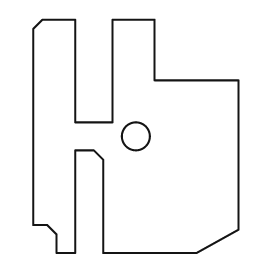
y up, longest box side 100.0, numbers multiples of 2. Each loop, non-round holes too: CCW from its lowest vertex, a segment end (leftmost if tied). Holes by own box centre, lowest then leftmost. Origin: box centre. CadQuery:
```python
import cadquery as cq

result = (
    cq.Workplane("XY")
    .moveTo(-34.0, -50.0)
    .lineTo(-26.0, -50.0)
    .lineTo(-26.0, -6.0)
    .lineTo(-18.0, -6.0)
    .lineTo(-14.0, -10.0)
    .lineTo(-14.0, -50.0)
    .lineTo(26.0, -50.0)
    .lineTo(44.0, -40.0)
    .lineTo(44.0, 24.0)
    .lineTo(8.0, 24.0)
    .lineTo(8.0, 50.0)
    .lineTo(-10.0, 50.0)
    .lineTo(-10.0, 6.0)
    .lineTo(-26.0, 6.0)
    .lineTo(-26.0, 50.0)
    .lineTo(-40.0, 50.0)
    .lineTo(-44.0, 46.0)
    .lineTo(-44.0, -38.0)
    .lineTo(-38.0, -38.0)
    .lineTo(-34.0, -42.0)
    .close()
    .moveTo(0.0, 0.0)
    .circle(6.0)
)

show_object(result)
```